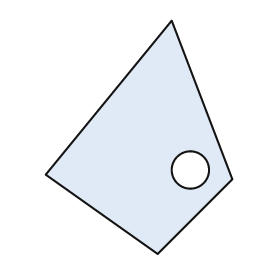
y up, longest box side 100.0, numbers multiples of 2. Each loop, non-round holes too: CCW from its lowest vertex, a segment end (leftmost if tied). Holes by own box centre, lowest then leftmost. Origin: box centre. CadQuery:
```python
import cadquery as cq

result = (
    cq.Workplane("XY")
    .moveTo(8.0, -50.0)
    .lineTo(40.0, -18.0)
    .lineTo(14.0, 50.0)
    .lineTo(-40.0, -16.0)
    .close()
    .moveTo(22.0, -14.0)
    .circle(8.0)
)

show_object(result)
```